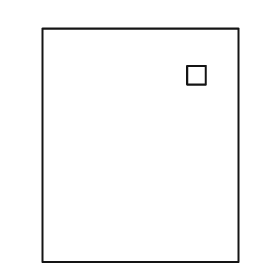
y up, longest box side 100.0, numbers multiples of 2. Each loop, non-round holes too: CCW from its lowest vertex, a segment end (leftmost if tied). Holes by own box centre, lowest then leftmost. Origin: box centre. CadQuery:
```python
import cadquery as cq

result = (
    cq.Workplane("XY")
    .moveTo(-42.0, -50.0)
    .lineTo(42.0, -50.0)
    .lineTo(42.0, 50.0)
    .lineTo(-42.0, 50.0)
    .close()
    .moveTo(20.0, 26.0)
    .lineTo(28.0, 26.0)
    .lineTo(28.0, 34.0)
    .lineTo(20.0, 34.0)
    .close()
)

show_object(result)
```